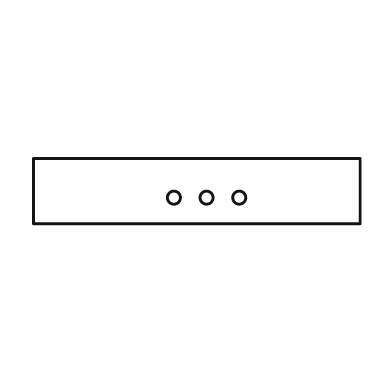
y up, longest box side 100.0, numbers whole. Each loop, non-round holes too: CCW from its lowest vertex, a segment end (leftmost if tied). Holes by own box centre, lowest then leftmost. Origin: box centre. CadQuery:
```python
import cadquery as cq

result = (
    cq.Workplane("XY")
    .moveTo(-50.0, -10.0)
    .lineTo(50.0, -10.0)
    .lineTo(50.0, 10.0)
    .lineTo(-50.0, 10.0)
    .close()
    .moveTo(-7.0, -2.0)
    .circle(2.0)
    .moveTo(3.0, -2.0)
    .circle(2.0)
    .moveTo(13.0, -2.0)
    .circle(2.0)
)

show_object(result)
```